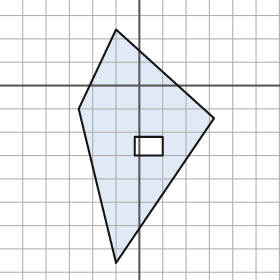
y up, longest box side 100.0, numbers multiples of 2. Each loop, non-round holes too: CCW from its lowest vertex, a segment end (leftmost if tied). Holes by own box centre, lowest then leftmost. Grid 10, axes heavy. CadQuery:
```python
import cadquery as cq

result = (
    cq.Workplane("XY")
    .moveTo(-10.0, -76.0)
    .lineTo(32.0, -14.0)
    .lineTo(-10.0, 24.0)
    .lineTo(-26.0, -10.0)
    .close()
    .moveTo(-2.0, -30.0)
    .lineTo(10.0, -30.0)
    .lineTo(10.0, -22.0)
    .lineTo(-2.0, -22.0)
    .close()
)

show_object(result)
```